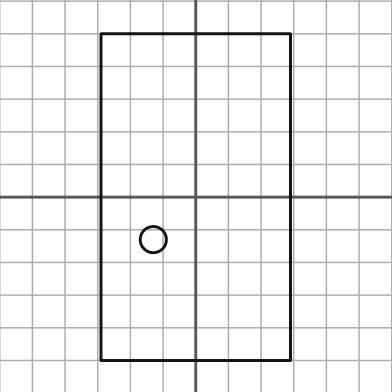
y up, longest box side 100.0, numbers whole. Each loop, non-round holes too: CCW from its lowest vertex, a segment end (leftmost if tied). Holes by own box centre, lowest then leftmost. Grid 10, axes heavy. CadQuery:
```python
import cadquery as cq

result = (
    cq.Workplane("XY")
    .moveTo(-29.0, -50.0)
    .lineTo(29.0, -50.0)
    .lineTo(29.0, 50.0)
    .lineTo(-29.0, 50.0)
    .close()
    .moveTo(-13.0, -13.0)
    .circle(4.0)
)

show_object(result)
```